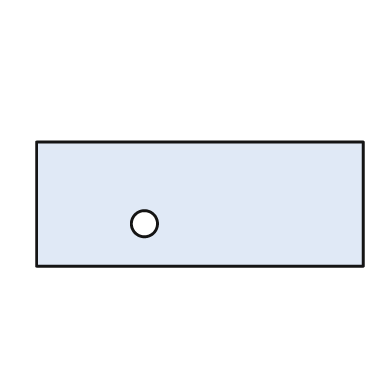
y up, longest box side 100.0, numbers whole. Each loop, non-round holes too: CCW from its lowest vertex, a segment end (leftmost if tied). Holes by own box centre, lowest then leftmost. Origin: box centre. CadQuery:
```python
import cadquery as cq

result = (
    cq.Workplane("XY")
    .moveTo(-50.0, -19.0)
    .lineTo(50.0, -19.0)
    .lineTo(50.0, 19.0)
    .lineTo(-50.0, 19.0)
    .close()
    .moveTo(-17.0, -6.0)
    .circle(4.0)
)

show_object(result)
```